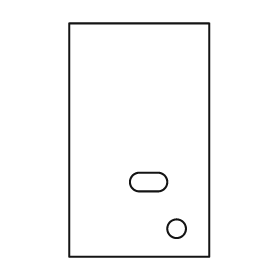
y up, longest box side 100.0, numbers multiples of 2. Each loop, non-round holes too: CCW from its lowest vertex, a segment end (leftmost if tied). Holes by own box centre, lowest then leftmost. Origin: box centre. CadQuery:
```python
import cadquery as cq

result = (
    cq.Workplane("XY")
    .moveTo(-30.0, -50.0)
    .lineTo(30.0, -50.0)
    .lineTo(30.0, 50.0)
    .lineTo(-30.0, 50.0)
    .close()
    .moveTo(16.0, -38.0)
    .circle(4.0)
    .moveTo(0.0, -22.0)
    .lineTo(8.0, -22.0)
    .threePointArc((12.0, -18.0), (8.0, -14.0))
    .lineTo(0.0, -14.0)
    .threePointArc((-4.0, -18.0), (0.0, -22.0))
    .close()
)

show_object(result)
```